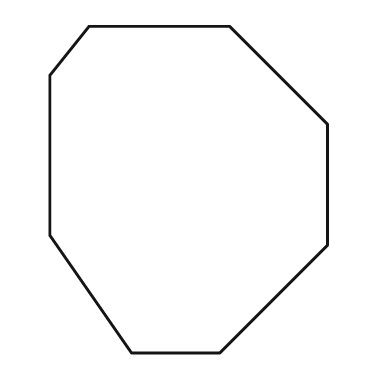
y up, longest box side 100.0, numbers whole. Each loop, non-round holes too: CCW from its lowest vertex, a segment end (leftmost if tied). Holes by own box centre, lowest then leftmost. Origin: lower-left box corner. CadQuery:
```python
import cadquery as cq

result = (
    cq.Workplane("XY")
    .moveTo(25.0, 0.0)
    .lineTo(52.0, 0.0)
    .lineTo(85.0, 33.0)
    .lineTo(85.0, 70.0)
    .lineTo(55.0, 100.0)
    .lineTo(12.0, 100.0)
    .lineTo(0.0, 85.0)
    .lineTo(0.0, 36.0)
    .close()
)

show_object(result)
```